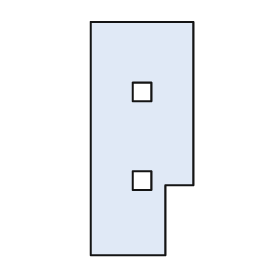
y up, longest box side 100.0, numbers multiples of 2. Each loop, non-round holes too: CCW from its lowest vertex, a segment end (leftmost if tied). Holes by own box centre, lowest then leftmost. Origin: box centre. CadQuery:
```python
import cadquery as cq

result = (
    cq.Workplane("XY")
    .moveTo(-22.0, -50.0)
    .lineTo(10.0, -50.0)
    .lineTo(10.0, -20.0)
    .lineTo(22.0, -20.0)
    .lineTo(22.0, 50.0)
    .lineTo(-22.0, 50.0)
    .close()
    .moveTo(-4.0, -22.0)
    .lineTo(4.0, -22.0)
    .lineTo(4.0, -14.0)
    .lineTo(-4.0, -14.0)
    .close()
    .moveTo(-4.0, 16.0)
    .lineTo(4.0, 16.0)
    .lineTo(4.0, 24.0)
    .lineTo(-4.0, 24.0)
    .close()
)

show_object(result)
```